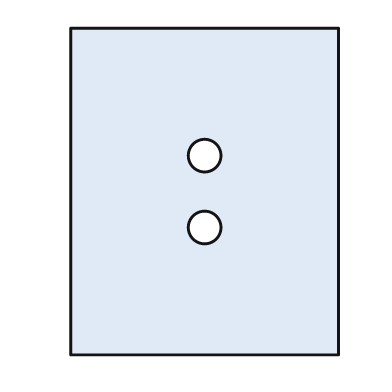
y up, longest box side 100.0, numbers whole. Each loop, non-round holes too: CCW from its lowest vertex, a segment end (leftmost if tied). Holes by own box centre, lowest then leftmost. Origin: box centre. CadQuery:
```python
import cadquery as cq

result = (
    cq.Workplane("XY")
    .moveTo(-41.0, -50.0)
    .lineTo(41.0, -50.0)
    .lineTo(41.0, 50.0)
    .lineTo(-41.0, 50.0)
    .close()
    .moveTo(0.0, -11.0)
    .circle(5.0)
    .moveTo(0.0, 11.0)
    .circle(5.0)
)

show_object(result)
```